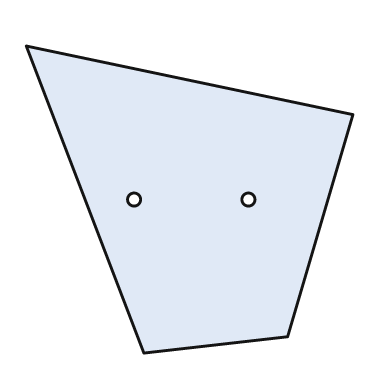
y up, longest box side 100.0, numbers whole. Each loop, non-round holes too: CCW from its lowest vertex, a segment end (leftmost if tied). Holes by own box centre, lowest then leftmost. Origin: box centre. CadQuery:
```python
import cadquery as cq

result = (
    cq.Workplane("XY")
    .moveTo(-14.0, -47.0)
    .lineTo(30.0, -42.0)
    .lineTo(50.0, 26.0)
    .lineTo(-50.0, 47.0)
    .close()
    .moveTo(-17.0, 0.0)
    .circle(2.0)
    .moveTo(18.0, 0.0)
    .circle(2.0)
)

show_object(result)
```